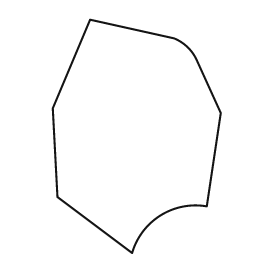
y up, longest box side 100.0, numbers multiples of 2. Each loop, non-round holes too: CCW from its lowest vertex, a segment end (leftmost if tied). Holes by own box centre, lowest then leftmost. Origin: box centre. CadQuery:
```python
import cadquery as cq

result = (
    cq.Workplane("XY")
    .moveTo(-2.0, -50.0)
    .threePointArc((10.0, -34.0), (30.0, -30.0))
    .lineTo(36.0, 10.0)
    .lineTo(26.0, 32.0)
    .threePointArc((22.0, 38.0), (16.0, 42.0))
    .lineTo(-20.0, 50.0)
    .lineTo(-36.0, 12.0)
    .lineTo(-34.0, -26.0)
    .close()
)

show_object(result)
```